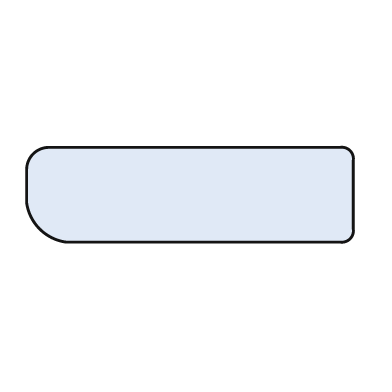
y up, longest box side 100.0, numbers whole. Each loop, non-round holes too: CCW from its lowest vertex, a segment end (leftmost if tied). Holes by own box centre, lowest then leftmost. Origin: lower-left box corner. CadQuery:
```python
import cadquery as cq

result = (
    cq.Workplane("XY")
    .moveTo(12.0, 0.0)
    .lineTo(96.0, 0.0)
    .threePointArc((99.0, 1.0), (100.0, 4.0))
    .lineTo(100.0, 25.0)
    .threePointArc((99.0, 28.0), (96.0, 29.0))
    .lineTo(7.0, 29.0)
    .threePointArc((2.0, 27.0), (0.0, 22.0))
    .lineTo(0.0, 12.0)
    .threePointArc((4.0, 4.0), (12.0, 0.0))
    .close()
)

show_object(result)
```